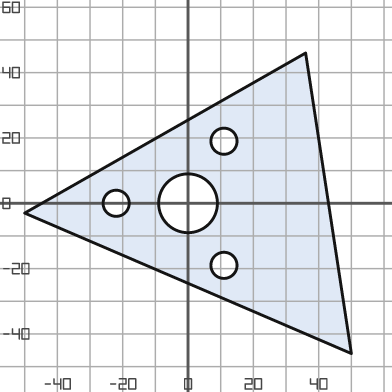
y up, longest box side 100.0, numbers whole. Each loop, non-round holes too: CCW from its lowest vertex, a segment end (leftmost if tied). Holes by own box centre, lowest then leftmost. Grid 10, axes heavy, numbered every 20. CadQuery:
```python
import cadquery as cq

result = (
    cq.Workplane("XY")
    .moveTo(50.0, -46.0)
    .lineTo(36.0, 46.0)
    .lineTo(-50.0, -3.0)
    .close()
    .moveTo(11.0, -19.0)
    .circle(4.0)
    .moveTo(-22.0, 0.0)
    .circle(4.0)
    .moveTo(0.0, 0.0)
    .circle(9.0)
    .moveTo(11.0, 19.0)
    .circle(4.0)
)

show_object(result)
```